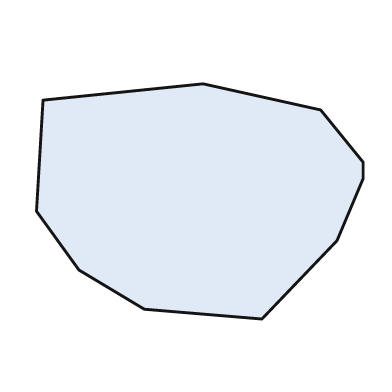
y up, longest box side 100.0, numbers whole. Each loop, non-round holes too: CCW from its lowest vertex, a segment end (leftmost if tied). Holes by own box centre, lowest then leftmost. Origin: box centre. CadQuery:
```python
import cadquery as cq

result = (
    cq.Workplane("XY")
    .moveTo(19.0, -36.0)
    .lineTo(42.0, -12.0)
    .lineTo(50.0, 7.0)
    .lineTo(50.0, 12.0)
    .lineTo(37.0, 28.0)
    .lineTo(1.0, 36.0)
    .lineTo(-48.0, 31.0)
    .lineTo(-50.0, -3.0)
    .lineTo(-37.0, -21.0)
    .lineTo(-17.0, -33.0)
    .close()
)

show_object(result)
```